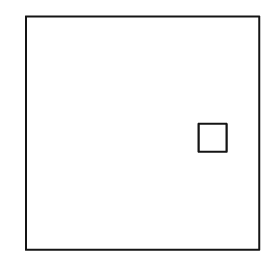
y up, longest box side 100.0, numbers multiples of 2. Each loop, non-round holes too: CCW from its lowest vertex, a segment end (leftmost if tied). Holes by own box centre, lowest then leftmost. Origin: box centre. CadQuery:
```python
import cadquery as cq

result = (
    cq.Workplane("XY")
    .moveTo(-50.0, -50.0)
    .lineTo(50.0, -50.0)
    .lineTo(50.0, 50.0)
    .lineTo(-50.0, 50.0)
    .close()
    .moveTo(24.0, -8.0)
    .lineTo(36.0, -8.0)
    .lineTo(36.0, 4.0)
    .lineTo(24.0, 4.0)
    .close()
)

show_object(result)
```